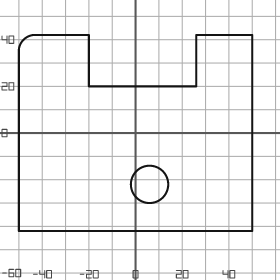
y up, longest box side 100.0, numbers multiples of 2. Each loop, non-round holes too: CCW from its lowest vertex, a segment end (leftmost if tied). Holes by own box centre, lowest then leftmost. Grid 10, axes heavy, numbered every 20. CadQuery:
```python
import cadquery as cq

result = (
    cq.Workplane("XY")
    .moveTo(-50.0, -42.0)
    .lineTo(50.0, -42.0)
    .lineTo(50.0, 42.0)
    .lineTo(26.0, 42.0)
    .lineTo(26.0, 20.0)
    .lineTo(-20.0, 20.0)
    .lineTo(-20.0, 42.0)
    .lineTo(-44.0, 42.0)
    .threePointArc((-48.0, 40.0), (-50.0, 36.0))
    .close()
    .moveTo(6.0, -22.0)
    .circle(8.0)
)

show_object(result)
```